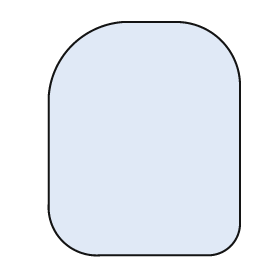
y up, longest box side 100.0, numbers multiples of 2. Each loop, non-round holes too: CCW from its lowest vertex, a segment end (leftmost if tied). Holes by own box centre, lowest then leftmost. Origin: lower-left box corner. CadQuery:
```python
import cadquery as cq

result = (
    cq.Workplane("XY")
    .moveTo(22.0, 0.0)
    .lineTo(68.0, 0.0)
    .threePointArc((78.0, 4.0), (82.0, 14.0))
    .lineTo(82.0, 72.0)
    .threePointArc((74.0, 92.0), (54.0, 100.0))
    .lineTo(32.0, 100.0)
    .threePointArc((10.0, 90.0), (0.0, 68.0))
    .lineTo(0.0, 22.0)
    .threePointArc((6.0, 6.0), (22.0, 0.0))
    .close()
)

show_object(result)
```